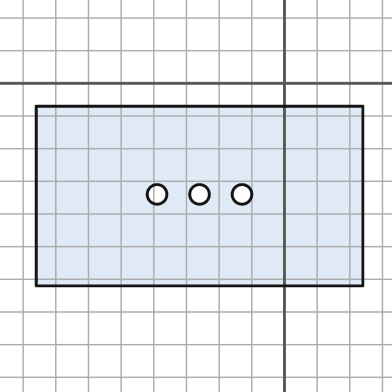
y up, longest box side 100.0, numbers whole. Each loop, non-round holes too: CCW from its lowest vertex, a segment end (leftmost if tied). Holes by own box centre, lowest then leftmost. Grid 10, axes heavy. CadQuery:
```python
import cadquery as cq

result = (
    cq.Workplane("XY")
    .moveTo(-76.0, -62.0)
    .lineTo(24.0, -62.0)
    .lineTo(24.0, -7.0)
    .lineTo(-76.0, -7.0)
    .close()
    .moveTo(-39.0, -34.0)
    .circle(3.0)
    .moveTo(-26.0, -34.0)
    .circle(3.0)
    .moveTo(-13.0, -34.0)
    .circle(3.0)
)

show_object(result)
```